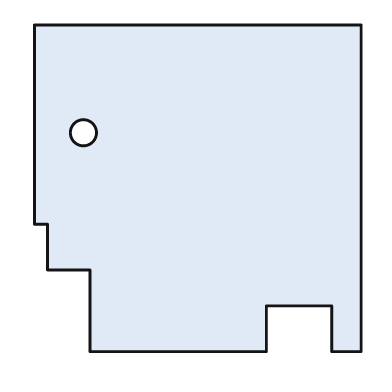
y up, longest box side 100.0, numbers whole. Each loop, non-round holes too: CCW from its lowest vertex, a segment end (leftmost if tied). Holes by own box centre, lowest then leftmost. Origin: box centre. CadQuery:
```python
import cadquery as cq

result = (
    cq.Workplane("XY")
    .moveTo(-33.0, -50.0)
    .lineTo(21.0, -50.0)
    .lineTo(21.0, -36.0)
    .lineTo(41.0, -36.0)
    .lineTo(41.0, -50.0)
    .lineTo(50.0, -50.0)
    .lineTo(50.0, 50.0)
    .lineTo(-50.0, 50.0)
    .lineTo(-50.0, -11.0)
    .lineTo(-46.0, -11.0)
    .lineTo(-46.0, -25.0)
    .lineTo(-33.0, -25.0)
    .close()
    .moveTo(-35.0, 17.0)
    .circle(4.0)
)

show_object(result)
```